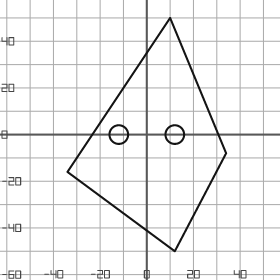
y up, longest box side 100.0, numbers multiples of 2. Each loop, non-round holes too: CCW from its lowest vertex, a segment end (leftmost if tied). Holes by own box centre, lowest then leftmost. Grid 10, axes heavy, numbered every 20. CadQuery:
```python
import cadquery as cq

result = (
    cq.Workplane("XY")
    .moveTo(12.0, -50.0)
    .lineTo(34.0, -8.0)
    .lineTo(10.0, 50.0)
    .lineTo(-34.0, -16.0)
    .close()
    .moveTo(-12.0, 0.0)
    .circle(4.0)
    .moveTo(12.0, 0.0)
    .circle(4.0)
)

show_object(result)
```